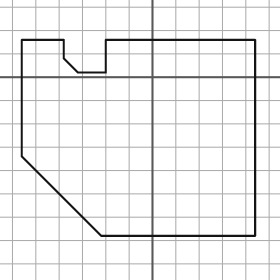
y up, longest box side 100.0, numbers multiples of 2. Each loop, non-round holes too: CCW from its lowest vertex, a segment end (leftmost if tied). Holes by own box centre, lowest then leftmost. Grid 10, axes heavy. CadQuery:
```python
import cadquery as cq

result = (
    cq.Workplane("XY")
    .moveTo(-22.0, -68.0)
    .lineTo(44.0, -68.0)
    .lineTo(44.0, 16.0)
    .lineTo(-20.0, 16.0)
    .lineTo(-20.0, 2.0)
    .lineTo(-32.0, 2.0)
    .lineTo(-38.0, 8.0)
    .lineTo(-38.0, 16.0)
    .lineTo(-56.0, 16.0)
    .lineTo(-56.0, -34.0)
    .close()
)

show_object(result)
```